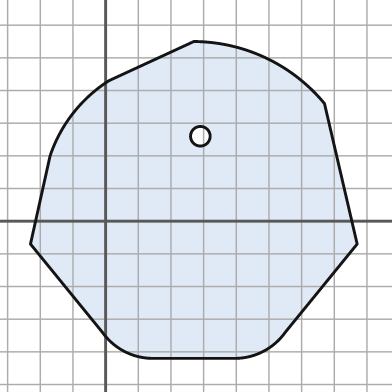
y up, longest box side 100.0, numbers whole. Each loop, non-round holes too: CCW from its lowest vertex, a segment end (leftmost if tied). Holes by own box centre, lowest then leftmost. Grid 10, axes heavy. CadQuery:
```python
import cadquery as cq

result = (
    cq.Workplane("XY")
    .moveTo(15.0, -42.0)
    .lineTo(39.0, -42.0)
    .threePointArc((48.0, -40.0), (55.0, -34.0))
    .lineTo(77.0, -7.0)
    .lineTo(67.0, 36.0)
    .threePointArc((49.0, 50.0), (27.0, 55.0))
    .lineTo(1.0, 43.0)
    .threePointArc((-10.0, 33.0), (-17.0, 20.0))
    .lineTo(-23.0, -7.0)
    .lineTo(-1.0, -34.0)
    .threePointArc((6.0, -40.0), (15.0, -42.0))
    .close()
    .moveTo(29.0, 26.0)
    .circle(3.0)
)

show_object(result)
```